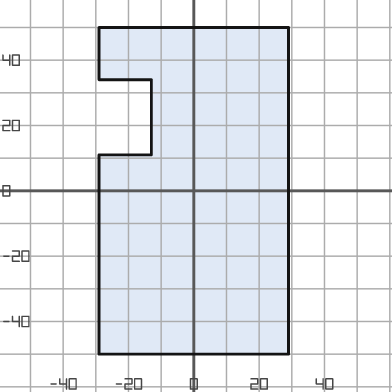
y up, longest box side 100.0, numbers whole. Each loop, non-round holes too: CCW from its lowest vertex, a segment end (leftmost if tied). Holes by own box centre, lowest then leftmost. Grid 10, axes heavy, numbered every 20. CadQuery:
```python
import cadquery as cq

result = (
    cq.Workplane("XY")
    .moveTo(-29.0, -50.0)
    .lineTo(29.0, -50.0)
    .lineTo(29.0, 50.0)
    .lineTo(-29.0, 50.0)
    .lineTo(-29.0, 34.0)
    .lineTo(-13.0, 34.0)
    .lineTo(-13.0, 11.0)
    .lineTo(-29.0, 11.0)
    .close()
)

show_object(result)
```